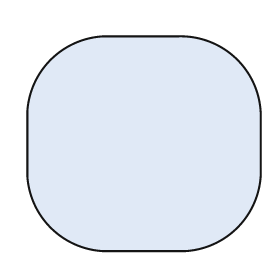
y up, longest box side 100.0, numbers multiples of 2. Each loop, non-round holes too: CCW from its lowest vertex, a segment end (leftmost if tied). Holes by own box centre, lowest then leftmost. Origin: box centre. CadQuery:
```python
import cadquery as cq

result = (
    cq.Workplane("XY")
    .moveTo(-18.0, -46.0)
    .lineTo(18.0, -46.0)
    .threePointArc((40.0, -36.0), (50.0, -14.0))
    .lineTo(50.0, 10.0)
    .threePointArc((40.0, 36.0), (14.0, 46.0))
    .lineTo(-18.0, 46.0)
    .threePointArc((-40.0, 36.0), (-50.0, 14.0))
    .lineTo(-50.0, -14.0)
    .threePointArc((-40.0, -36.0), (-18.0, -46.0))
    .close()
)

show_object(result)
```